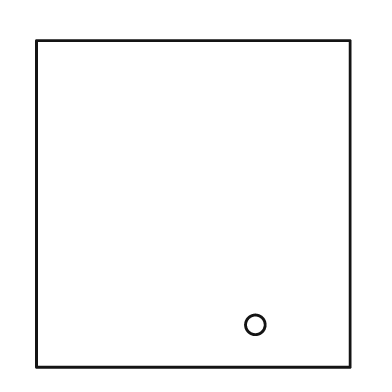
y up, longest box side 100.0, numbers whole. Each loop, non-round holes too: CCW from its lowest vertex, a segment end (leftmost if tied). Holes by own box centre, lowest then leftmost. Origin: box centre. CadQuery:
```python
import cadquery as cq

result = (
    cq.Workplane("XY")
    .moveTo(-48.0, -50.0)
    .lineTo(48.0, -50.0)
    .lineTo(48.0, 50.0)
    .lineTo(-48.0, 50.0)
    .close()
    .moveTo(19.0, -37.0)
    .circle(3.0)
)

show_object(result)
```